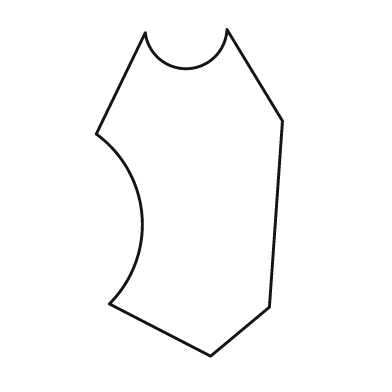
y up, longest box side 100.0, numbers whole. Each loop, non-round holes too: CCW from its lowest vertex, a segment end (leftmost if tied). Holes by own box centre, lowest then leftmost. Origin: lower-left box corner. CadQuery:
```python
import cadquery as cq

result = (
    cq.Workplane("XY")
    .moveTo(35.0, 0.0)
    .lineTo(53.0, 15.0)
    .lineTo(57.0, 72.0)
    .lineTo(40.0, 100.0)
    .threePointArc((28.0, 88.0), (15.0, 99.0))
    .lineTo(0.0, 68.0)
    .threePointArc((14.0, 43.0), (4.0, 16.0))
    .close()
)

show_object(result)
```